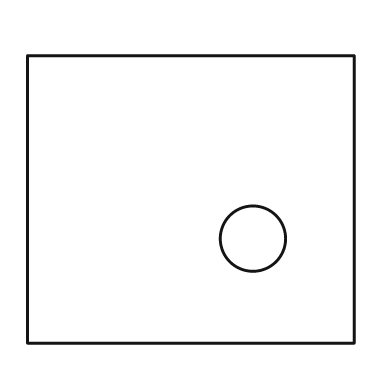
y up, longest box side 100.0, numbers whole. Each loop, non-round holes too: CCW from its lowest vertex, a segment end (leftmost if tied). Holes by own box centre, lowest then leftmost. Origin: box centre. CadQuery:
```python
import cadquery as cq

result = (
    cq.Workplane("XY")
    .moveTo(-50.0, -44.0)
    .lineTo(50.0, -44.0)
    .lineTo(50.0, 44.0)
    .lineTo(-50.0, 44.0)
    .close()
    .moveTo(19.0, -12.0)
    .circle(10.0)
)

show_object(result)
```